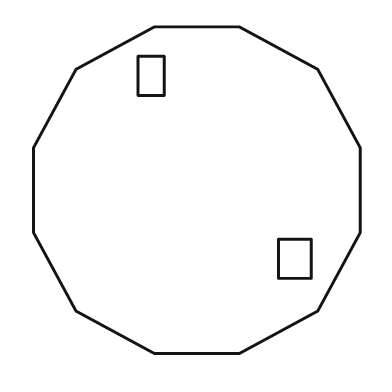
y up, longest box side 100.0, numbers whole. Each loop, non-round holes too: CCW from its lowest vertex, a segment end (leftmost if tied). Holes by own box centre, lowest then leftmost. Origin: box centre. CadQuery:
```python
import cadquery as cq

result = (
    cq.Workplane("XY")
    .moveTo(-13.0, -50.0)
    .lineTo(13.0, -50.0)
    .lineTo(37.0, -37.0)
    .lineTo(50.0, -13.0)
    .lineTo(50.0, 13.0)
    .lineTo(37.0, 37.0)
    .lineTo(13.0, 50.0)
    .lineTo(-13.0, 50.0)
    .lineTo(-37.0, 37.0)
    .lineTo(-50.0, 13.0)
    .lineTo(-50.0, -13.0)
    .lineTo(-37.0, -37.0)
    .close()
    .moveTo(25.0, -27.0)
    .lineTo(35.0, -27.0)
    .lineTo(35.0, -15.0)
    .lineTo(25.0, -15.0)
    .close()
    .moveTo(-18.0, 29.0)
    .lineTo(-10.0, 29.0)
    .lineTo(-10.0, 41.0)
    .lineTo(-18.0, 41.0)
    .close()
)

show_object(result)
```